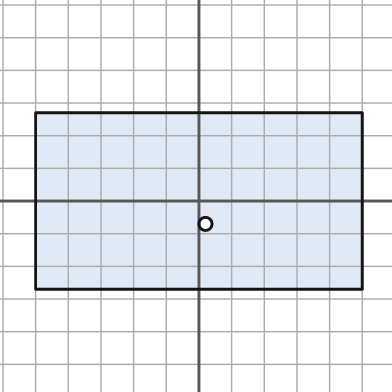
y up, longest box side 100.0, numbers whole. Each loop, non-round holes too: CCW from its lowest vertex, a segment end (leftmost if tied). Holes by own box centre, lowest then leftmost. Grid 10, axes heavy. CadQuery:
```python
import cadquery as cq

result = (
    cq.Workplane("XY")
    .moveTo(-50.0, -27.0)
    .lineTo(50.0, -27.0)
    .lineTo(50.0, 27.0)
    .lineTo(-50.0, 27.0)
    .close()
    .moveTo(2.0, -7.0)
    .circle(2.0)
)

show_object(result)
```